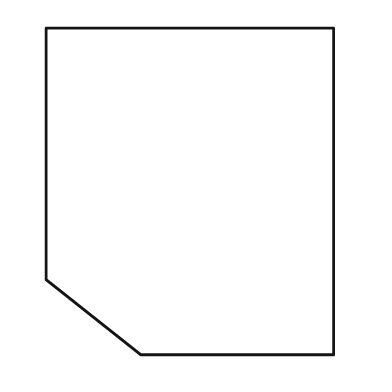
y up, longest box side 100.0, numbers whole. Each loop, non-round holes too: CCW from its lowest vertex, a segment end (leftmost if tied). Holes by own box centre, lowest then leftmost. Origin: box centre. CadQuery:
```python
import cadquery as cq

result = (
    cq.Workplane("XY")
    .moveTo(-15.0, -50.0)
    .lineTo(44.0, -50.0)
    .lineTo(44.0, 50.0)
    .lineTo(-44.0, 50.0)
    .lineTo(-44.0, -27.0)
    .close()
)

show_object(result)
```